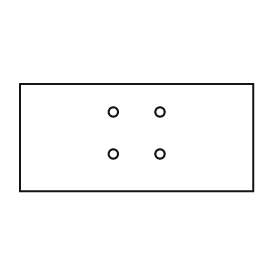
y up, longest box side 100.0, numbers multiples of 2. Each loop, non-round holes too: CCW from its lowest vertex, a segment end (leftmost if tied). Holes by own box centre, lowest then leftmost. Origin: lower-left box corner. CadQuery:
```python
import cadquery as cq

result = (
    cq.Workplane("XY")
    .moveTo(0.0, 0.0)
    .lineTo(100.0, 0.0)
    .lineTo(100.0, 46.0)
    .lineTo(0.0, 46.0)
    .close()
    .moveTo(40.0, 16.0)
    .circle(2.0)
    .moveTo(60.0, 16.0)
    .circle(2.0)
    .moveTo(40.0, 34.0)
    .circle(2.0)
    .moveTo(60.0, 34.0)
    .circle(2.0)
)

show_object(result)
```